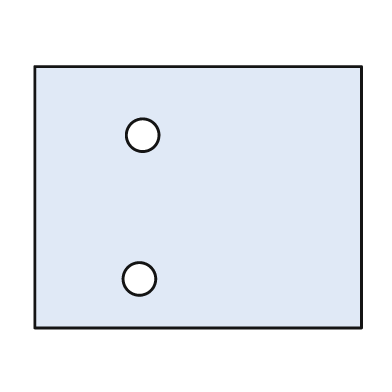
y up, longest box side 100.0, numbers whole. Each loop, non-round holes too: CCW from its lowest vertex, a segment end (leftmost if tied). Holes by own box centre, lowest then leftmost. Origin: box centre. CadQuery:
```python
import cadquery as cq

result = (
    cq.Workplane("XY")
    .moveTo(-50.0, -40.0)
    .lineTo(50.0, -40.0)
    .lineTo(50.0, 40.0)
    .lineTo(-50.0, 40.0)
    .close()
    .moveTo(-18.0, -25.0)
    .circle(5.0)
    .moveTo(-17.0, 19.0)
    .circle(5.0)
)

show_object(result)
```